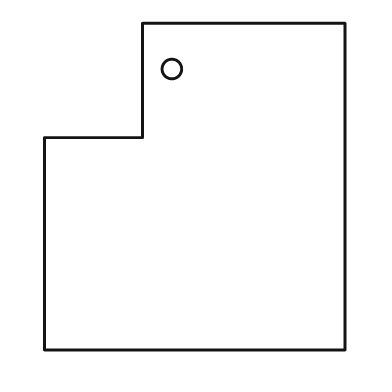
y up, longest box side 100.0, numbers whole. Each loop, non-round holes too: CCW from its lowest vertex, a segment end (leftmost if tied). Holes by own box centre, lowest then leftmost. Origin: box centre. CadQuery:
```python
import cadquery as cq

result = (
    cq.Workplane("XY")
    .moveTo(-46.0, -50.0)
    .lineTo(46.0, -50.0)
    .lineTo(46.0, 50.0)
    .lineTo(-16.0, 50.0)
    .lineTo(-16.0, 15.0)
    .lineTo(-46.0, 15.0)
    .close()
    .moveTo(-7.0, 36.0)
    .circle(3.0)
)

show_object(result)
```